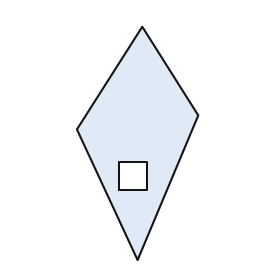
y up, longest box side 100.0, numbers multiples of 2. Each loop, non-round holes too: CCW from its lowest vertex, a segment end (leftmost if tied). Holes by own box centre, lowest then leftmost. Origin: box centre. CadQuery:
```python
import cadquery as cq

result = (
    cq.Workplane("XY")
    .moveTo(0.0, -50.0)
    .lineTo(26.0, 12.0)
    .lineTo(2.0, 50.0)
    .lineTo(-26.0, 6.0)
    .close()
    .moveTo(-8.0, -20.0)
    .lineTo(4.0, -20.0)
    .lineTo(4.0, -8.0)
    .lineTo(-8.0, -8.0)
    .close()
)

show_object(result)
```